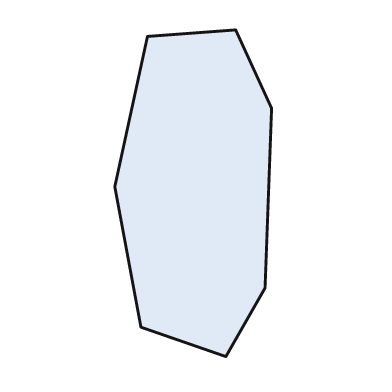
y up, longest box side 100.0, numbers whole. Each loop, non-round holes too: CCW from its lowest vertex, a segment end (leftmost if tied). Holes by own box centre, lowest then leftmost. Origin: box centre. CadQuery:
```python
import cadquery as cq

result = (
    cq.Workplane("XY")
    .moveTo(10.0, -50.0)
    .lineTo(22.0, -29.0)
    .lineTo(24.0, 26.0)
    .lineTo(13.0, 50.0)
    .lineTo(-14.0, 48.0)
    .lineTo(-24.0, 2.0)
    .lineTo(-16.0, -41.0)
    .close()
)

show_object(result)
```